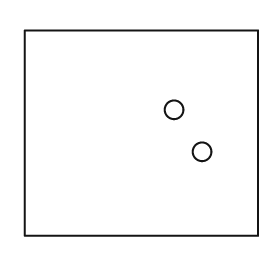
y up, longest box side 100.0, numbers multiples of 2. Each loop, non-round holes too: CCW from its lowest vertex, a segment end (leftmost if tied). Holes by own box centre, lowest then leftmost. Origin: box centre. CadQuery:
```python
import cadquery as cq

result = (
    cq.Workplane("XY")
    .moveTo(-50.0, -44.0)
    .lineTo(50.0, -44.0)
    .lineTo(50.0, 44.0)
    .lineTo(-50.0, 44.0)
    .close()
    .moveTo(26.0, -8.0)
    .circle(4.0)
    .moveTo(14.0, 10.0)
    .circle(4.0)
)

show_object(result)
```